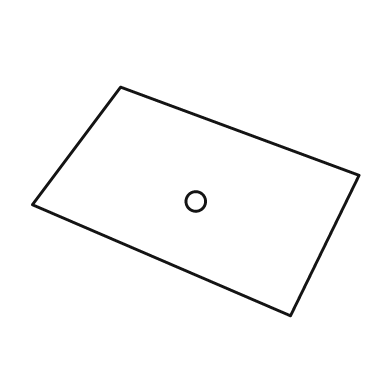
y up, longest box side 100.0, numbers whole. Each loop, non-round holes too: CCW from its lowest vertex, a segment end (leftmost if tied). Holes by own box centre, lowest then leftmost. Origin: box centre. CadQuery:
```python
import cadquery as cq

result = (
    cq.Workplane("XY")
    .moveTo(29.0, -35.0)
    .lineTo(50.0, 8.0)
    .lineTo(-23.0, 35.0)
    .lineTo(-50.0, -1.0)
    .close()
    .moveTo(0.0, 0.0)
    .circle(3.0)
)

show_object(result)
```